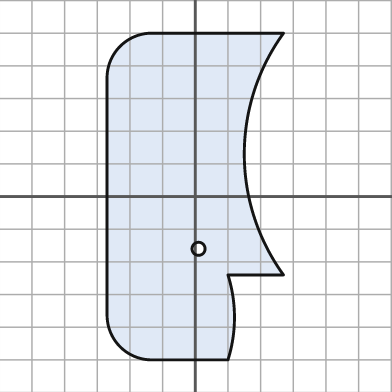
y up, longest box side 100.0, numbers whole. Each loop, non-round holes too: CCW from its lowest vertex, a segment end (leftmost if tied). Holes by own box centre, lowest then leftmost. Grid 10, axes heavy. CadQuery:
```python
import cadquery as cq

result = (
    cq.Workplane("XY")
    .moveTo(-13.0, -50.0)
    .lineTo(10.0, -50.0)
    .threePointArc((12.0, -37.0), (10.0, -24.0))
    .lineTo(27.0, -24.0)
    .threePointArc((15.0, 13.0), (27.0, 50.0))
    .lineTo(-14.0, 50.0)
    .threePointArc((-23.0, 46.0), (-27.0, 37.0))
    .lineTo(-27.0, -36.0)
    .threePointArc((-23.0, -46.0), (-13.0, -50.0))
    .close()
    .moveTo(1.0, -16.0)
    .circle(2.0)
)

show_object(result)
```